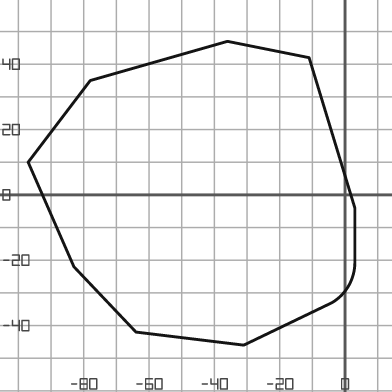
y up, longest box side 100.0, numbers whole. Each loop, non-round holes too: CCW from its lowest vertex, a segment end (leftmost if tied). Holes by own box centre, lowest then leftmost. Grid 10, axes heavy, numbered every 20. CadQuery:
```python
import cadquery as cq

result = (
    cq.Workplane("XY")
    .moveTo(-31.0, -46.0)
    .lineTo(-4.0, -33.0)
    .threePointArc((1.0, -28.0), (3.0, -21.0))
    .lineTo(3.0, -4.0)
    .lineTo(-11.0, 42.0)
    .lineTo(-36.0, 47.0)
    .lineTo(-78.0, 35.0)
    .lineTo(-97.0, 10.0)
    .lineTo(-83.0, -22.0)
    .lineTo(-64.0, -42.0)
    .close()
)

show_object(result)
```